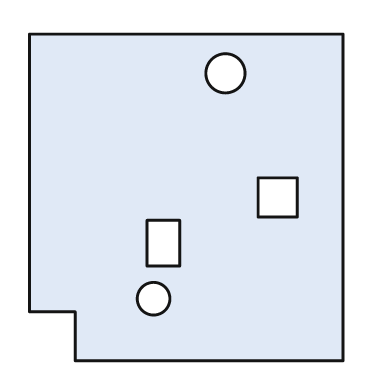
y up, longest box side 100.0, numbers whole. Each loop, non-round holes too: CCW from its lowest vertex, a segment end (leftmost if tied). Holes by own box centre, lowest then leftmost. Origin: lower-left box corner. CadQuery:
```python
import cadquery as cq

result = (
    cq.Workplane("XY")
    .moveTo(14.0, 0.0)
    .lineTo(96.0, 0.0)
    .lineTo(96.0, 100.0)
    .lineTo(0.0, 100.0)
    .lineTo(0.0, 15.0)
    .lineTo(14.0, 15.0)
    .close()
    .moveTo(38.0, 19.0)
    .circle(5.0)
    .moveTo(36.0, 29.0)
    .lineTo(46.0, 29.0)
    .lineTo(46.0, 43.0)
    .lineTo(36.0, 43.0)
    .close()
    .moveTo(70.0, 44.0)
    .lineTo(82.0, 44.0)
    .lineTo(82.0, 56.0)
    .lineTo(70.0, 56.0)
    .close()
    .moveTo(60.0, 88.0)
    .circle(6.0)
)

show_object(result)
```